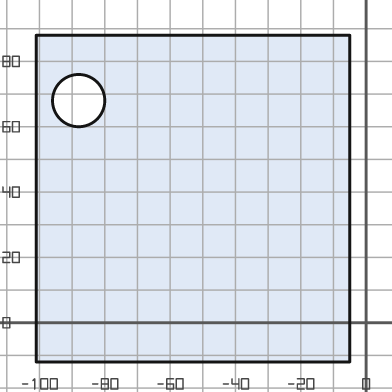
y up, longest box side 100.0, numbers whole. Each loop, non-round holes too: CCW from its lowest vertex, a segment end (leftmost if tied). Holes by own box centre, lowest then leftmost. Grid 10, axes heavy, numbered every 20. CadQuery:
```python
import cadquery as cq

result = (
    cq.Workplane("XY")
    .moveTo(-101.0, -12.0)
    .lineTo(-5.0, -12.0)
    .lineTo(-5.0, 88.0)
    .lineTo(-101.0, 88.0)
    .close()
    .moveTo(-88.0, 68.0)
    .circle(8.0)
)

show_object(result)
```